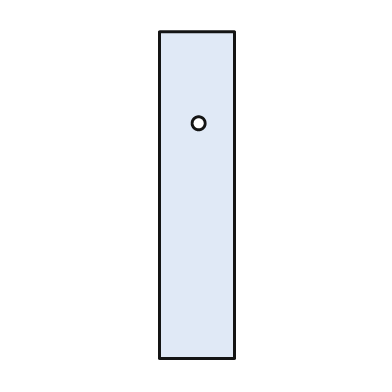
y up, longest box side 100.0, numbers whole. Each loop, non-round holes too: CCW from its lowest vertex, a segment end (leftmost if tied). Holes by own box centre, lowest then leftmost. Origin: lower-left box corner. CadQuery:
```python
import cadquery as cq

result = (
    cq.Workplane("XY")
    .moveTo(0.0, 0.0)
    .lineTo(23.0, 0.0)
    .lineTo(23.0, 100.0)
    .lineTo(0.0, 100.0)
    .close()
    .moveTo(12.0, 72.0)
    .circle(2.0)
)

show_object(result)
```